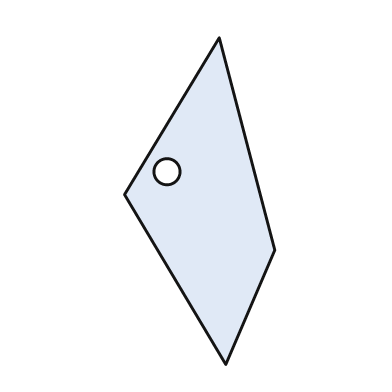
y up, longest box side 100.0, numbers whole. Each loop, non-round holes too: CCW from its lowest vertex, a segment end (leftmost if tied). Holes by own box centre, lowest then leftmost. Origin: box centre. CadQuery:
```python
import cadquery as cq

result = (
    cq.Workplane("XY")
    .moveTo(8.0, -50.0)
    .lineTo(23.0, -15.0)
    .lineTo(6.0, 50.0)
    .lineTo(-23.0, 2.0)
    .close()
    .moveTo(-10.0, 9.0)
    .circle(4.0)
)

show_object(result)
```